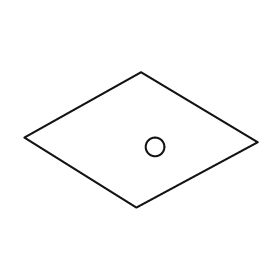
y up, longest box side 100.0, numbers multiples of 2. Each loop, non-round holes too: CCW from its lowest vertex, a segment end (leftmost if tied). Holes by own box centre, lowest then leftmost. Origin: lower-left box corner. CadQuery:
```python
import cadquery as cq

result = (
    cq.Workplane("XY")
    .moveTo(48.0, 0.0)
    .lineTo(100.0, 28.0)
    .lineTo(50.0, 58.0)
    .lineTo(0.0, 30.0)
    .close()
    .moveTo(56.0, 26.0)
    .circle(4.0)
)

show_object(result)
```